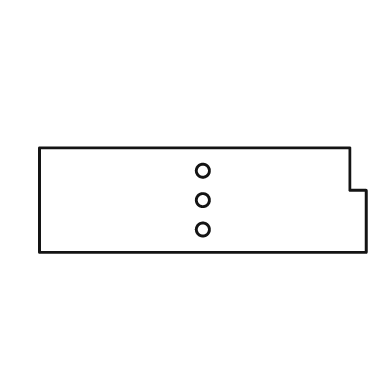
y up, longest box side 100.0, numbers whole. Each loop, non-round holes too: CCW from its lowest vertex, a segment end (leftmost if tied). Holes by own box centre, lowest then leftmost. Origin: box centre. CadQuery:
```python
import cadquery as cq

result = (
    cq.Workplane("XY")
    .moveTo(-50.0, -16.0)
    .lineTo(50.0, -16.0)
    .lineTo(50.0, 3.0)
    .lineTo(45.0, 3.0)
    .lineTo(45.0, 16.0)
    .lineTo(-50.0, 16.0)
    .close()
    .moveTo(0.0, -9.0)
    .circle(2.0)
    .moveTo(0.0, 0.0)
    .circle(2.0)
    .moveTo(0.0, 9.0)
    .circle(2.0)
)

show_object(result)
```